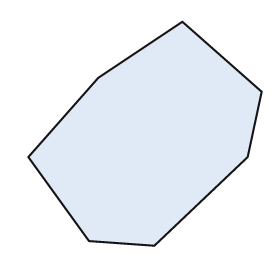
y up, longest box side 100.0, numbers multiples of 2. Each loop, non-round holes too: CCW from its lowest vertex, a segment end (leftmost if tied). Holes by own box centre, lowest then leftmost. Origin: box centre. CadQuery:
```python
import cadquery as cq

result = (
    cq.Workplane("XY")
    .moveTo(4.0, -48.0)
    .lineTo(44.0, -10.0)
    .lineTo(50.0, 18.0)
    .lineTo(16.0, 48.0)
    .lineTo(-20.0, 24.0)
    .lineTo(-50.0, -10.0)
    .lineTo(-24.0, -46.0)
    .close()
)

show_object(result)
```